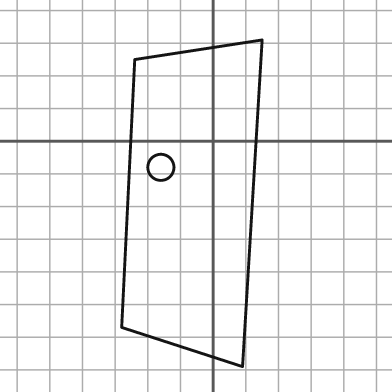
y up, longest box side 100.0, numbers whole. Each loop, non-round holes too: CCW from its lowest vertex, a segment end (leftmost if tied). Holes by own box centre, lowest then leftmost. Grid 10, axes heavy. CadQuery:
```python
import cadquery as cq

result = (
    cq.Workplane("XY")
    .moveTo(9.0, -69.0)
    .lineTo(15.0, 31.0)
    .lineTo(-24.0, 25.0)
    .lineTo(-28.0, -57.0)
    .close()
    .moveTo(-16.0, -8.0)
    .circle(4.0)
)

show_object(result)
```